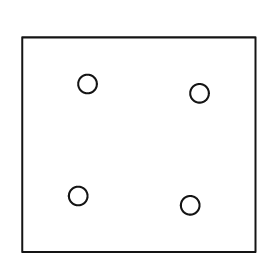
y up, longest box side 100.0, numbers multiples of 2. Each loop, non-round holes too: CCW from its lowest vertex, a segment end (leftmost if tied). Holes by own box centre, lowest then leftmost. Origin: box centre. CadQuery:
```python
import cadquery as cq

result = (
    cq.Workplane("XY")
    .moveTo(-50.0, -46.0)
    .lineTo(50.0, -46.0)
    .lineTo(50.0, 46.0)
    .lineTo(-50.0, 46.0)
    .close()
    .moveTo(22.0, -26.0)
    .circle(4.0)
    .moveTo(-26.0, -22.0)
    .circle(4.0)
    .moveTo(26.0, 22.0)
    .circle(4.0)
    .moveTo(-22.0, 26.0)
    .circle(4.0)
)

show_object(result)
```